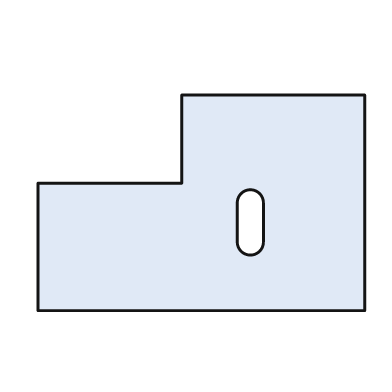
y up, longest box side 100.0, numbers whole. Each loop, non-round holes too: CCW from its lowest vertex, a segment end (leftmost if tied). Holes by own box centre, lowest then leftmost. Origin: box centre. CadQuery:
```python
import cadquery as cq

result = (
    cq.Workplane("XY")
    .moveTo(-50.0, -33.0)
    .lineTo(50.0, -33.0)
    .lineTo(50.0, 33.0)
    .lineTo(-6.0, 33.0)
    .lineTo(-6.0, 6.0)
    .lineTo(-50.0, 6.0)
    .close()
    .moveTo(11.0, -12.0)
    .threePointArc((15.0, -16.0), (19.0, -12.0))
    .lineTo(19.0, 0.0)
    .threePointArc((15.0, 4.0), (11.0, 0.0))
    .close()
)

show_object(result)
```